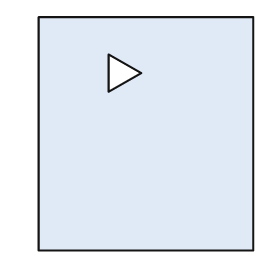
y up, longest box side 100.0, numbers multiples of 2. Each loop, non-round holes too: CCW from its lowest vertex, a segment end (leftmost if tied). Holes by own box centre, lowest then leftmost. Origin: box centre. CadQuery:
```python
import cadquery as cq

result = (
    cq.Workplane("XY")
    .moveTo(-46.0, -50.0)
    .lineTo(46.0, -50.0)
    .lineTo(46.0, 50.0)
    .lineTo(-46.0, 50.0)
    .close()
    .moveTo(-16.0, 18.0)
    .lineTo(-2.0, 26.0)
    .lineTo(-16.0, 34.0)
    .close()
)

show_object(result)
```